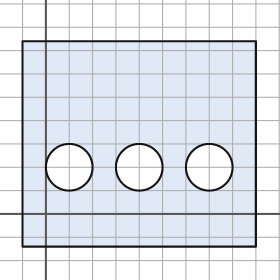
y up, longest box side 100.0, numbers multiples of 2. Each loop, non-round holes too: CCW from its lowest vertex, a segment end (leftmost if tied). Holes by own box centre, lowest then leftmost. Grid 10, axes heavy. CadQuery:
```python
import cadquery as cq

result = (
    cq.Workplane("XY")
    .moveTo(-10.0, -14.0)
    .lineTo(90.0, -14.0)
    .lineTo(90.0, 74.0)
    .lineTo(-10.0, 74.0)
    .close()
    .moveTo(10.0, 20.0)
    .circle(10.0)
    .moveTo(40.0, 20.0)
    .circle(10.0)
    .moveTo(70.0, 20.0)
    .circle(10.0)
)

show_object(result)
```